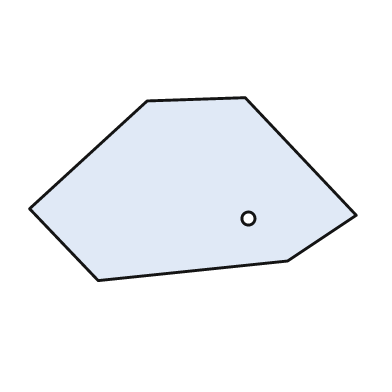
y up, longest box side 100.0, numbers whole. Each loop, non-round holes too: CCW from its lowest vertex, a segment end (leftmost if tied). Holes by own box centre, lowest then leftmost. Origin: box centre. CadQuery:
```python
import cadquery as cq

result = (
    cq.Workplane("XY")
    .moveTo(-29.0, -28.0)
    .lineTo(29.0, -22.0)
    .lineTo(50.0, -8.0)
    .lineTo(16.0, 28.0)
    .lineTo(-14.0, 27.0)
    .lineTo(-50.0, -6.0)
    .close()
    .moveTo(17.0, -9.0)
    .circle(2.0)
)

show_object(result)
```